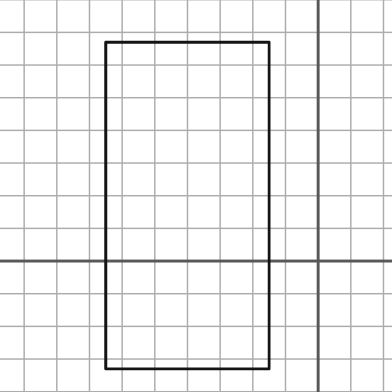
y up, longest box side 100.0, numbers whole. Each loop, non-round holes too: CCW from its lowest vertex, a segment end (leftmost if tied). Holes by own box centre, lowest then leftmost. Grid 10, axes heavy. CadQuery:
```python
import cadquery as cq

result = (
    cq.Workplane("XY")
    .moveTo(-65.0, -33.0)
    .lineTo(-15.0, -33.0)
    .lineTo(-15.0, 67.0)
    .lineTo(-65.0, 67.0)
    .close()
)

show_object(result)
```